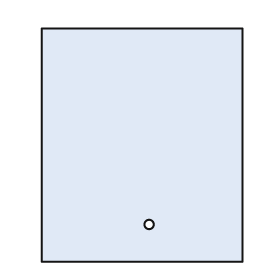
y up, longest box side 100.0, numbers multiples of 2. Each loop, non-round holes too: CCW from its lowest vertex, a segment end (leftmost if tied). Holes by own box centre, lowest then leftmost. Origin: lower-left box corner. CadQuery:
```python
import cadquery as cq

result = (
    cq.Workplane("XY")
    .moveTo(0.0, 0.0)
    .lineTo(86.0, 0.0)
    .lineTo(86.0, 100.0)
    .lineTo(0.0, 100.0)
    .close()
    .moveTo(46.0, 16.0)
    .circle(2.0)
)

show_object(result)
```